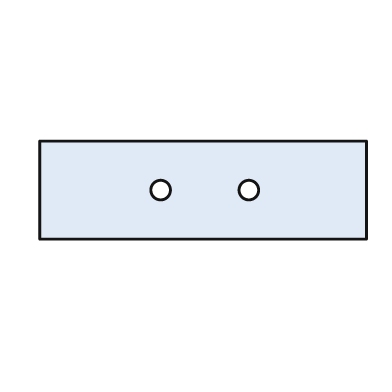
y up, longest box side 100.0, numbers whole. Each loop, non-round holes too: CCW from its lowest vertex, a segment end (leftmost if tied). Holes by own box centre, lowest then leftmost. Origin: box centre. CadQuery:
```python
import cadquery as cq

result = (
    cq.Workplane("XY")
    .moveTo(-50.0, -15.0)
    .lineTo(50.0, -15.0)
    .lineTo(50.0, 15.0)
    .lineTo(-50.0, 15.0)
    .close()
    .moveTo(-13.0, 0.0)
    .circle(3.0)
    .moveTo(14.0, 0.0)
    .circle(3.0)
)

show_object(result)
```